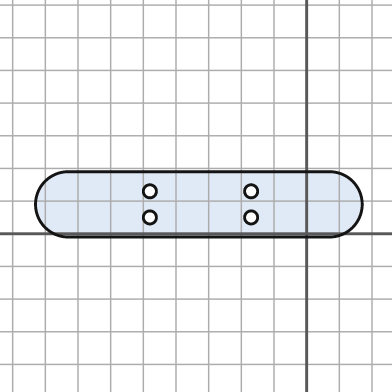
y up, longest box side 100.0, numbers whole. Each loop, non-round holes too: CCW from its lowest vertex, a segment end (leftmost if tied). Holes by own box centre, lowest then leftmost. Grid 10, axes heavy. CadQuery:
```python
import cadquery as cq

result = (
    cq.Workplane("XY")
    .moveTo(-73.0, -1.0)
    .lineTo(7.0, -1.0)
    .threePointArc((17.0, 9.0), (7.0, 19.0))
    .lineTo(-73.0, 19.0)
    .threePointArc((-83.0, 9.0), (-73.0, -1.0))
    .close()
    .moveTo(-48.0, 5.0)
    .circle(2.0)
    .moveTo(-17.0, 5.0)
    .circle(2.0)
    .moveTo(-48.0, 13.0)
    .circle(2.0)
    .moveTo(-17.0, 13.0)
    .circle(2.0)
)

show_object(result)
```